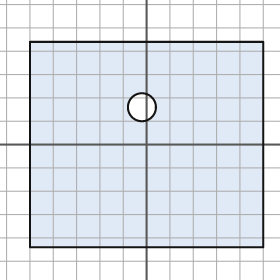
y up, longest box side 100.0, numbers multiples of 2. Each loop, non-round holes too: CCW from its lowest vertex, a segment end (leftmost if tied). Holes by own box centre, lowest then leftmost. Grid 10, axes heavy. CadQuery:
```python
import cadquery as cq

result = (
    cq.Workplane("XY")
    .moveTo(-50.0, -44.0)
    .lineTo(50.0, -44.0)
    .lineTo(50.0, 44.0)
    .lineTo(-50.0, 44.0)
    .close()
    .moveTo(-2.0, 16.0)
    .circle(6.0)
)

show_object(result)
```